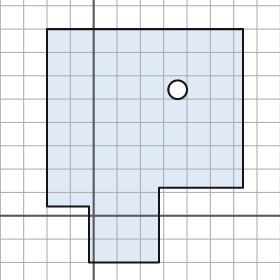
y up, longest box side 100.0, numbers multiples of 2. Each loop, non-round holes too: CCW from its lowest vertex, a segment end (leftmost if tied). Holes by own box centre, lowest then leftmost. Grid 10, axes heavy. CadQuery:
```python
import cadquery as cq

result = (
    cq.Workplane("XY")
    .moveTo(-2.0, -20.0)
    .lineTo(28.0, -20.0)
    .lineTo(28.0, 12.0)
    .lineTo(64.0, 12.0)
    .lineTo(64.0, 80.0)
    .lineTo(-20.0, 80.0)
    .lineTo(-20.0, 4.0)
    .lineTo(-2.0, 4.0)
    .close()
    .moveTo(36.0, 54.0)
    .circle(4.0)
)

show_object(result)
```